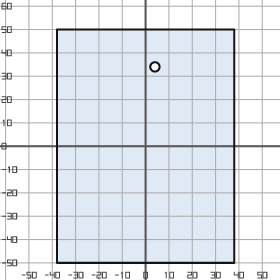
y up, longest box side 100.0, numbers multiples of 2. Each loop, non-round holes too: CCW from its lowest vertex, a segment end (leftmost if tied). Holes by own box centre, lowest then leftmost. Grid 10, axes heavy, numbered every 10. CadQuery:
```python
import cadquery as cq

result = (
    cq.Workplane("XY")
    .moveTo(-38.0, -50.0)
    .lineTo(38.0, -50.0)
    .lineTo(38.0, 50.0)
    .lineTo(-38.0, 50.0)
    .close()
    .moveTo(4.0, 34.0)
    .circle(2.0)
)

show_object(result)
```